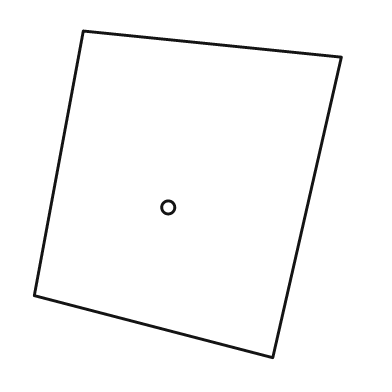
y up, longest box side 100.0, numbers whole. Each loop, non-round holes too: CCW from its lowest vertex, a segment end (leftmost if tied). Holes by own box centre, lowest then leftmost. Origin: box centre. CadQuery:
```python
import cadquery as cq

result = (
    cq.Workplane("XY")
    .moveTo(26.0, -50.0)
    .lineTo(47.0, 42.0)
    .lineTo(-32.0, 50.0)
    .lineTo(-47.0, -31.0)
    .close()
    .moveTo(-6.0, -4.0)
    .circle(2.0)
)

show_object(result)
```